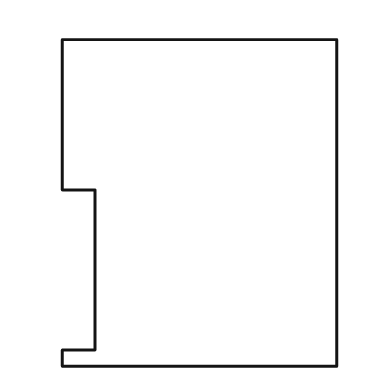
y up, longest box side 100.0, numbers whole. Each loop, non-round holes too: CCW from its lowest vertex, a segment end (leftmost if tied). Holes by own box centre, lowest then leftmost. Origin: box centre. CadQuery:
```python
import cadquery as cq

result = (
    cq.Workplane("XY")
    .moveTo(-42.0, -50.0)
    .lineTo(42.0, -50.0)
    .lineTo(42.0, 50.0)
    .lineTo(-42.0, 50.0)
    .lineTo(-42.0, 4.0)
    .lineTo(-32.0, 4.0)
    .lineTo(-32.0, -45.0)
    .lineTo(-42.0, -45.0)
    .close()
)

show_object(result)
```